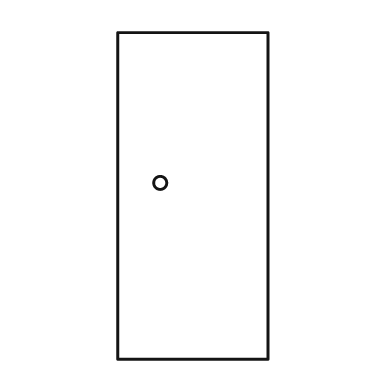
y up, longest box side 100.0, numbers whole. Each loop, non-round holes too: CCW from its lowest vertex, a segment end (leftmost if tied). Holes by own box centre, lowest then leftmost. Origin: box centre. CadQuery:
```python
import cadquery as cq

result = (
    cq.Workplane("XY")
    .moveTo(-23.0, -50.0)
    .lineTo(23.0, -50.0)
    .lineTo(23.0, 50.0)
    .lineTo(-23.0, 50.0)
    .close()
    .moveTo(-10.0, 4.0)
    .circle(2.0)
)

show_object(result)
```